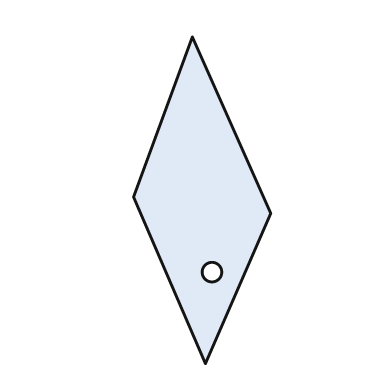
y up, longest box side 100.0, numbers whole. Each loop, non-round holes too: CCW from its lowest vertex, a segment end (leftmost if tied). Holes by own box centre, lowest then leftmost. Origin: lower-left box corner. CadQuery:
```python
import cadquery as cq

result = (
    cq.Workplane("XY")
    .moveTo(22.0, 0.0)
    .lineTo(42.0, 46.0)
    .lineTo(18.0, 100.0)
    .lineTo(0.0, 51.0)
    .close()
    .moveTo(24.0, 28.0)
    .circle(3.0)
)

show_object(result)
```